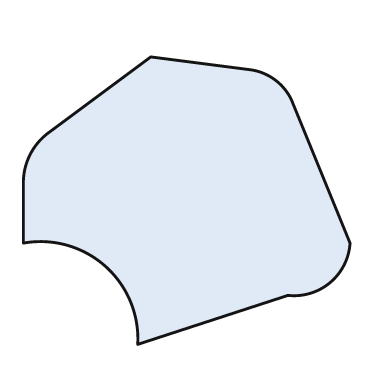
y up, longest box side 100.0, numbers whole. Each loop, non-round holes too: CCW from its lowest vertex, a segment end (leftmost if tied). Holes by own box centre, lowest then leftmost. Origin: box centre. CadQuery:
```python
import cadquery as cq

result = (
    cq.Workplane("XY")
    .moveTo(-15.0, -44.0)
    .lineTo(31.0, -29.0)
    .threePointArc((44.0, -25.0), (50.0, -13.0))
    .lineTo(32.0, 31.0)
    .threePointArc((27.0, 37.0), (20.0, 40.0))
    .lineTo(-11.0, 44.0)
    .lineTo(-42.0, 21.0)
    .threePointArc((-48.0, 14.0), (-50.0, 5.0))
    .lineTo(-50.0, -13.0)
    .threePointArc((-25.0, -20.0), (-15.0, -44.0))
    .close()
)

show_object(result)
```